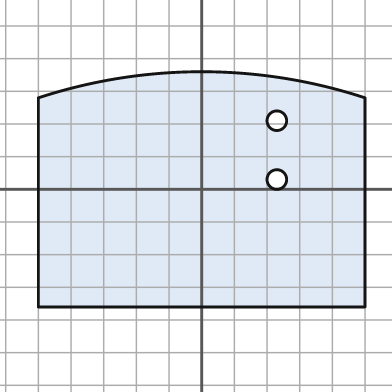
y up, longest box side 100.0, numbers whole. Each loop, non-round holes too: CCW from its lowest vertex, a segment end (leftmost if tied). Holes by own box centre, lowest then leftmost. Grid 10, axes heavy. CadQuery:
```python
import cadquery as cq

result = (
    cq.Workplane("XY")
    .moveTo(-50.0, -36.0)
    .lineTo(50.0, -36.0)
    .lineTo(50.0, 28.0)
    .threePointArc((0.0, 36.0), (-50.0, 28.0))
    .close()
    .moveTo(23.0, 3.0)
    .circle(3.0)
    .moveTo(23.0, 21.0)
    .circle(3.0)
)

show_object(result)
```